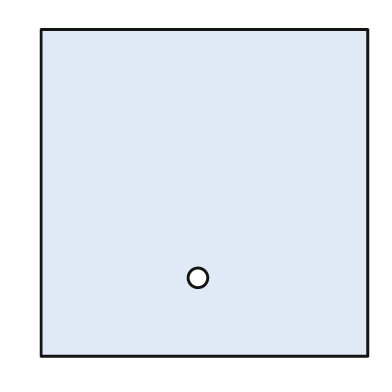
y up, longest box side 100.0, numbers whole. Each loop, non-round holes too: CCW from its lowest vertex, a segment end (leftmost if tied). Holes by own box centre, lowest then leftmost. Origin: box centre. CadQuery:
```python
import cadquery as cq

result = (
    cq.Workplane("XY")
    .moveTo(-50.0, -50.0)
    .lineTo(50.0, -50.0)
    .lineTo(50.0, 50.0)
    .lineTo(-50.0, 50.0)
    .close()
    .moveTo(-2.0, -26.0)
    .circle(3.0)
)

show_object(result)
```